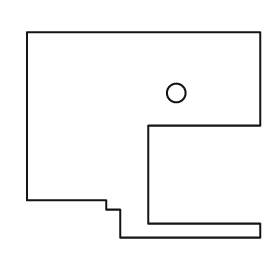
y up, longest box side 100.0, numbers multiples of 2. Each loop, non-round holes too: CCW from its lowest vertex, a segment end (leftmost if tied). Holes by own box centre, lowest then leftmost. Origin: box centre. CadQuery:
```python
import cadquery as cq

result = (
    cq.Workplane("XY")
    .moveTo(-10.0, -44.0)
    .lineTo(50.0, -44.0)
    .lineTo(50.0, -38.0)
    .lineTo(2.0, -38.0)
    .lineTo(2.0, 4.0)
    .lineTo(50.0, 4.0)
    .lineTo(50.0, 44.0)
    .lineTo(-50.0, 44.0)
    .lineTo(-50.0, -28.0)
    .lineTo(-16.0, -28.0)
    .lineTo(-16.0, -32.0)
    .lineTo(-10.0, -32.0)
    .close()
    .moveTo(14.0, 18.0)
    .circle(4.0)
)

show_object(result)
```